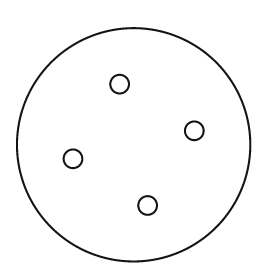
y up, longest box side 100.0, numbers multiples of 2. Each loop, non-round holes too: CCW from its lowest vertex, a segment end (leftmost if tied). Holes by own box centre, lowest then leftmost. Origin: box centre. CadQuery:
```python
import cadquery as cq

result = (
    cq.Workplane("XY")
    .moveTo(0.0, 0.0)
    .circle(50.0)
    .moveTo(6.0, -26.0)
    .circle(4.0)
    .moveTo(-26.0, -6.0)
    .circle(4.0)
    .moveTo(26.0, 6.0)
    .circle(4.0)
    .moveTo(-6.0, 26.0)
    .circle(4.0)
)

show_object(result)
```